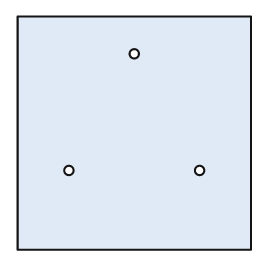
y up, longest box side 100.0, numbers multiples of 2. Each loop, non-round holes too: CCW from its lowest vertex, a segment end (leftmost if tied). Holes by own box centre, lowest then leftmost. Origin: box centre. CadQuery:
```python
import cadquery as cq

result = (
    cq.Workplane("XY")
    .moveTo(-50.0, -50.0)
    .lineTo(50.0, -50.0)
    .lineTo(50.0, 50.0)
    .lineTo(-50.0, 50.0)
    .close()
    .moveTo(-28.0, -16.0)
    .circle(2.0)
    .moveTo(28.0, -16.0)
    .circle(2.0)
    .moveTo(0.0, 34.0)
    .circle(2.0)
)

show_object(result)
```